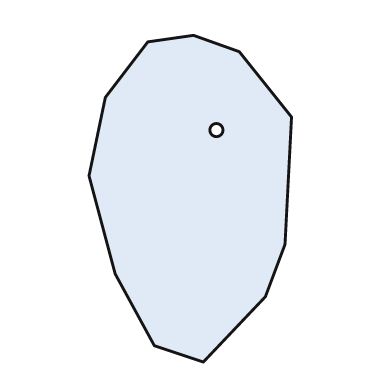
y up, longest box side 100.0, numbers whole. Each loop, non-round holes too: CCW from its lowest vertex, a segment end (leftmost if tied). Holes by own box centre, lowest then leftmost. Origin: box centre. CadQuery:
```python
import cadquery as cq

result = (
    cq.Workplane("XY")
    .moveTo(4.0, -50.0)
    .lineTo(23.0, -30.0)
    .lineTo(29.0, -14.0)
    .lineTo(31.0, 25.0)
    .lineTo(15.0, 45.0)
    .lineTo(1.0, 50.0)
    .lineTo(-13.0, 48.0)
    .lineTo(-26.0, 31.0)
    .lineTo(-31.0, 7.0)
    .lineTo(-23.0, -23.0)
    .lineTo(-11.0, -45.0)
    .close()
    .moveTo(8.0, 21.0)
    .circle(2.0)
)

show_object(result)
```